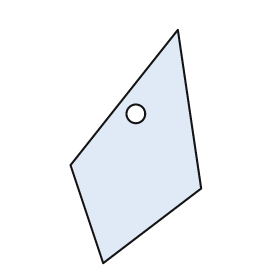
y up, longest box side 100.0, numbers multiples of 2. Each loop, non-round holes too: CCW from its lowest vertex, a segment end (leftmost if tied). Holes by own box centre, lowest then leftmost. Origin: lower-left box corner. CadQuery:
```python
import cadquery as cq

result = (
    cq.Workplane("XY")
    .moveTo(14.0, 0.0)
    .lineTo(56.0, 32.0)
    .lineTo(46.0, 100.0)
    .lineTo(0.0, 42.0)
    .close()
    .moveTo(28.0, 64.0)
    .circle(4.0)
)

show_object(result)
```